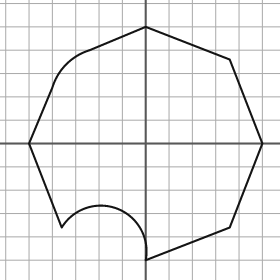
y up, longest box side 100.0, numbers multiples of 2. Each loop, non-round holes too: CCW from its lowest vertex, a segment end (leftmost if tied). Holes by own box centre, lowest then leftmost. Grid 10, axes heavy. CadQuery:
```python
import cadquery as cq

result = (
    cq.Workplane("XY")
    .moveTo(0.0, -50.0)
    .lineTo(36.0, -36.0)
    .lineTo(50.0, 0.0)
    .lineTo(36.0, 36.0)
    .lineTo(0.0, 50.0)
    .lineTo(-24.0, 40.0)
    .threePointArc((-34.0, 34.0), (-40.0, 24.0))
    .lineTo(-50.0, 0.0)
    .lineTo(-36.0, -36.0)
    .threePointArc((-12.0, -28.0), (0.0, -50.0))
    .close()
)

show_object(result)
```